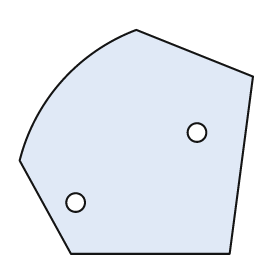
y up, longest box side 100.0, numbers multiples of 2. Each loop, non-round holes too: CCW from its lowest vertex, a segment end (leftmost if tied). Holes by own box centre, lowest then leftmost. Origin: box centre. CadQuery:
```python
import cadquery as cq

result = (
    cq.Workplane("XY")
    .moveTo(-28.0, -48.0)
    .lineTo(40.0, -48.0)
    .lineTo(50.0, 28.0)
    .lineTo(0.0, 48.0)
    .threePointArc((-32.0, 26.0), (-50.0, -8.0))
    .close()
    .moveTo(-26.0, -26.0)
    .circle(4.0)
    .moveTo(26.0, 4.0)
    .circle(4.0)
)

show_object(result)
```